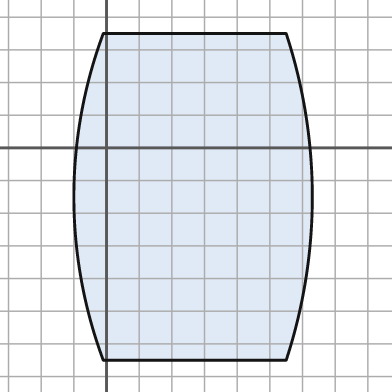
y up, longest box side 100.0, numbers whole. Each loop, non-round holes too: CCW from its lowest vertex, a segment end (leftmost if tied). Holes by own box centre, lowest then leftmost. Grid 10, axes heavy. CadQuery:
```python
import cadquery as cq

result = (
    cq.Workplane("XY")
    .moveTo(-1.0, -65.0)
    .lineTo(55.0, -65.0)
    .threePointArc((63.0, -15.0), (55.0, 35.0))
    .lineTo(-1.0, 35.0)
    .threePointArc((-10.0, -15.0), (-1.0, -65.0))
    .close()
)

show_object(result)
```